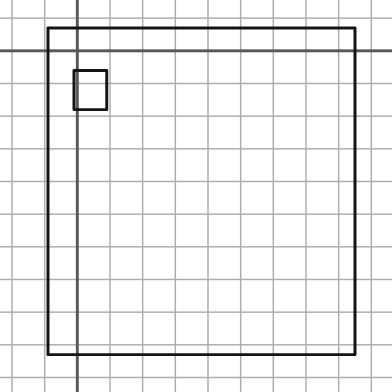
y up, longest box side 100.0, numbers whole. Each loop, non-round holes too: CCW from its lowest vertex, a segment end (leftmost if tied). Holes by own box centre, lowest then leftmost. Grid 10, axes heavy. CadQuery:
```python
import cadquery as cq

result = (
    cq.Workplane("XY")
    .moveTo(-9.0, -93.0)
    .lineTo(85.0, -93.0)
    .lineTo(85.0, 7.0)
    .lineTo(-9.0, 7.0)
    .close()
    .moveTo(-1.0, -18.0)
    .lineTo(9.0, -18.0)
    .lineTo(9.0, -6.0)
    .lineTo(-1.0, -6.0)
    .close()
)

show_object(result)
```